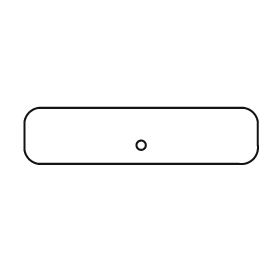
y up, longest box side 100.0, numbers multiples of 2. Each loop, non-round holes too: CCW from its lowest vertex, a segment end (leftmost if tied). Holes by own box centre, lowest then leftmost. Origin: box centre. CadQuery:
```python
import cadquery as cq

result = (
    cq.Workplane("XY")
    .moveTo(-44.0, -12.0)
    .lineTo(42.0, -12.0)
    .threePointArc((48.0, -10.0), (50.0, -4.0))
    .lineTo(50.0, 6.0)
    .threePointArc((48.0, 10.0), (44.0, 12.0))
    .lineTo(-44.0, 12.0)
    .threePointArc((-48.0, 10.0), (-50.0, 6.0))
    .lineTo(-50.0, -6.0)
    .threePointArc((-48.0, -10.0), (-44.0, -12.0))
    .close()
    .moveTo(0.0, -4.0)
    .circle(2.0)
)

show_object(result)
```